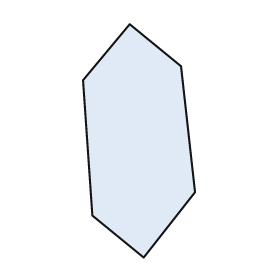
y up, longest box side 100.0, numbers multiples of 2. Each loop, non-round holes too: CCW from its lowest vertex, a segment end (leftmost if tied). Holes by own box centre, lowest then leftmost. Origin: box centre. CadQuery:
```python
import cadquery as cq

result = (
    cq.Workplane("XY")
    .moveTo(2.0, -50.0)
    .lineTo(24.0, -22.0)
    .lineTo(18.0, 32.0)
    .lineTo(-4.0, 50.0)
    .lineTo(-24.0, 26.0)
    .lineTo(-20.0, -32.0)
    .close()
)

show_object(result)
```